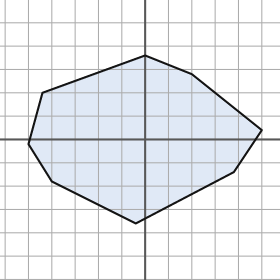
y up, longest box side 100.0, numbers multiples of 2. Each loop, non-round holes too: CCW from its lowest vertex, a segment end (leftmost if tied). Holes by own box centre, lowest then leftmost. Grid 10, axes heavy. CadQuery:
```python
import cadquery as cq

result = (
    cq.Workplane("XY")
    .moveTo(-4.0, -36.0)
    .lineTo(38.0, -14.0)
    .lineTo(50.0, 4.0)
    .lineTo(20.0, 28.0)
    .lineTo(0.0, 36.0)
    .lineTo(-44.0, 20.0)
    .lineTo(-50.0, -2.0)
    .lineTo(-40.0, -18.0)
    .close()
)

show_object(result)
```